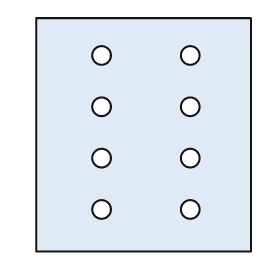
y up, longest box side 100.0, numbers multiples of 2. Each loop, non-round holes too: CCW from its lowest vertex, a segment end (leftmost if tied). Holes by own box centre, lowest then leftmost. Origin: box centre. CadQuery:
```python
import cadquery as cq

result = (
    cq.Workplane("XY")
    .moveTo(-46.0, -50.0)
    .lineTo(46.0, -50.0)
    .lineTo(46.0, 50.0)
    .lineTo(-46.0, 50.0)
    .close()
    .moveTo(-18.0, -32.0)
    .circle(4.0)
    .moveTo(20.0, -32.0)
    .circle(4.0)
    .moveTo(-18.0, -10.0)
    .circle(4.0)
    .moveTo(20.0, -10.0)
    .circle(4.0)
    .moveTo(-18.0, 12.0)
    .circle(4.0)
    .moveTo(20.0, 12.0)
    .circle(4.0)
    .moveTo(-18.0, 34.0)
    .circle(4.0)
    .moveTo(20.0, 34.0)
    .circle(4.0)
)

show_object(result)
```